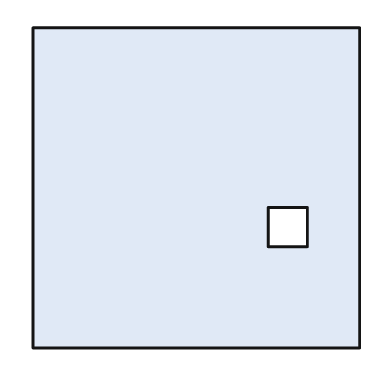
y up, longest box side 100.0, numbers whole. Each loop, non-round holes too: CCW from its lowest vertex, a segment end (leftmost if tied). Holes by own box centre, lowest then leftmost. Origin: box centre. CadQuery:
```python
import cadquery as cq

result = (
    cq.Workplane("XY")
    .moveTo(-50.0, -49.0)
    .lineTo(50.0, -49.0)
    .lineTo(50.0, 49.0)
    .lineTo(-50.0, 49.0)
    .close()
    .moveTo(22.0, -18.0)
    .lineTo(34.0, -18.0)
    .lineTo(34.0, -6.0)
    .lineTo(22.0, -6.0)
    .close()
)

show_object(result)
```